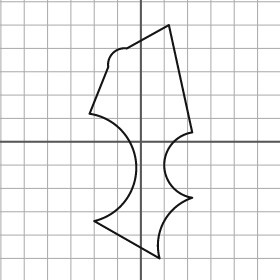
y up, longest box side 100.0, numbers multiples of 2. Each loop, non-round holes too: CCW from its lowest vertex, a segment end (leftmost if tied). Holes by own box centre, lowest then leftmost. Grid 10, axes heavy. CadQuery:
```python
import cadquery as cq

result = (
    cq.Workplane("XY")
    .moveTo(8.0, -50.0)
    .threePointArc((10.0, -34.0), (22.0, -24.0))
    .threePointArc((10.0, -10.0), (22.0, 4.0))
    .lineTo(12.0, 50.0)
    .lineTo(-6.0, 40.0)
    .threePointArc((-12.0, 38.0), (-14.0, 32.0))
    .lineTo(-22.0, 12.0)
    .threePointArc((-2.0, -10.0), (-20.0, -34.0))
    .close()
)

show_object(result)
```